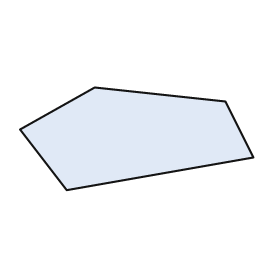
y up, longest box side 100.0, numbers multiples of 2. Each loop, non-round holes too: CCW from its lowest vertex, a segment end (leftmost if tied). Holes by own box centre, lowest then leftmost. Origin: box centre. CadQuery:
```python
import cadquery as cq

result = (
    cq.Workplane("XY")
    .moveTo(-30.0, -22.0)
    .lineTo(50.0, -8.0)
    .lineTo(38.0, 16.0)
    .lineTo(-18.0, 22.0)
    .lineTo(-50.0, 4.0)
    .close()
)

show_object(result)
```